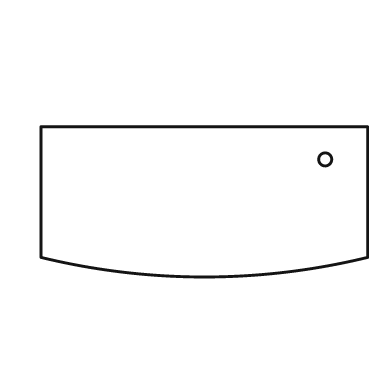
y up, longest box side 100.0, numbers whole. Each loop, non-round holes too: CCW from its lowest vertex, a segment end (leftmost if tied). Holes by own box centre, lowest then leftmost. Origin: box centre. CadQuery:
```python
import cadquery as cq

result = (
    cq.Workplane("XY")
    .moveTo(-50.0, -17.0)
    .threePointArc((0.0, -23.0), (50.0, -17.0))
    .lineTo(50.0, 23.0)
    .lineTo(-50.0, 23.0)
    .close()
    .moveTo(37.0, 13.0)
    .circle(2.0)
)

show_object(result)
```